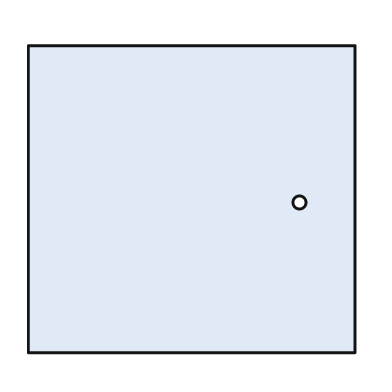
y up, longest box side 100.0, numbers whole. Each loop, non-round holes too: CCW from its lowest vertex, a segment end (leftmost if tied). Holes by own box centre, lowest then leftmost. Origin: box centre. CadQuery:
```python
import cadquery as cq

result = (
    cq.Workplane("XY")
    .moveTo(-50.0, -47.0)
    .lineTo(50.0, -47.0)
    .lineTo(50.0, 47.0)
    .lineTo(-50.0, 47.0)
    .close()
    .moveTo(33.0, -1.0)
    .circle(2.0)
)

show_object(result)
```